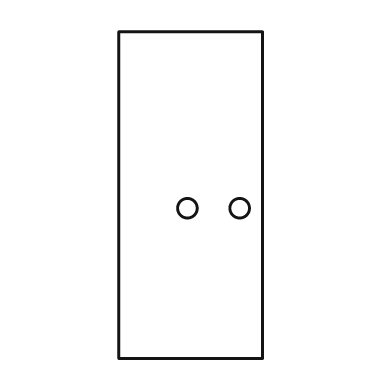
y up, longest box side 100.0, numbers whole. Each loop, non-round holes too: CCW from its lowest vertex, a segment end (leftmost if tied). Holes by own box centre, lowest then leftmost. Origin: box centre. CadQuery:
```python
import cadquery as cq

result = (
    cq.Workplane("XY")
    .moveTo(-22.0, -50.0)
    .lineTo(22.0, -50.0)
    .lineTo(22.0, 50.0)
    .lineTo(-22.0, 50.0)
    .close()
    .moveTo(-1.0, -4.0)
    .circle(3.0)
    .moveTo(15.0, -4.0)
    .circle(3.0)
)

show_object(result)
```